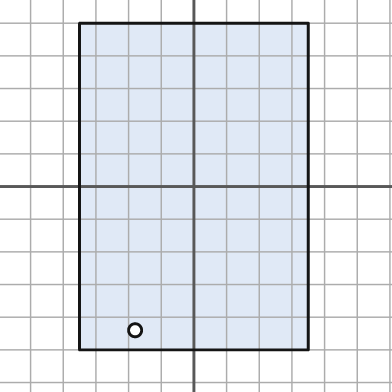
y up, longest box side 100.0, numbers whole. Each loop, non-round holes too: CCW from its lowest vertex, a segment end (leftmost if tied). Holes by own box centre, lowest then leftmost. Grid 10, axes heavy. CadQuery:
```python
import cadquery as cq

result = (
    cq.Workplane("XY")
    .moveTo(-35.0, -50.0)
    .lineTo(35.0, -50.0)
    .lineTo(35.0, 50.0)
    .lineTo(-35.0, 50.0)
    .close()
    .moveTo(-18.0, -44.0)
    .circle(2.0)
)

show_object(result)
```